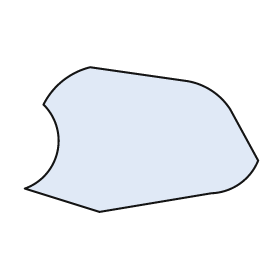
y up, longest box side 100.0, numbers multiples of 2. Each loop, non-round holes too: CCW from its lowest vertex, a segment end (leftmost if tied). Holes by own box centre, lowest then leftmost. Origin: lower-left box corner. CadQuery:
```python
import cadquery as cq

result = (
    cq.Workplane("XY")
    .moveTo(32.0, 0.0)
    .lineTo(80.0, 8.0)
    .threePointArc((92.0, 12.0), (100.0, 22.0))
    .lineTo(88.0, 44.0)
    .threePointArc((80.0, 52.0), (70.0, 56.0))
    .lineTo(28.0, 62.0)
    .threePointArc((16.0, 56.0), (8.0, 46.0))
    .threePointArc((14.0, 26.0), (0.0, 10.0))
    .close()
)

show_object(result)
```